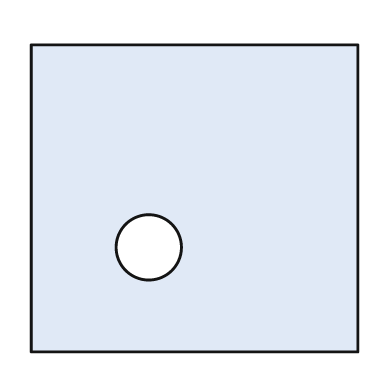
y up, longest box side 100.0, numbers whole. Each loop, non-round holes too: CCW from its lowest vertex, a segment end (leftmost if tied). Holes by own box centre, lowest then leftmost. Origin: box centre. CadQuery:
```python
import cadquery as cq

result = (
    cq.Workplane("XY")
    .moveTo(-50.0, -47.0)
    .lineTo(50.0, -47.0)
    .lineTo(50.0, 47.0)
    .lineTo(-50.0, 47.0)
    .close()
    .moveTo(-14.0, -15.0)
    .circle(10.0)
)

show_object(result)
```